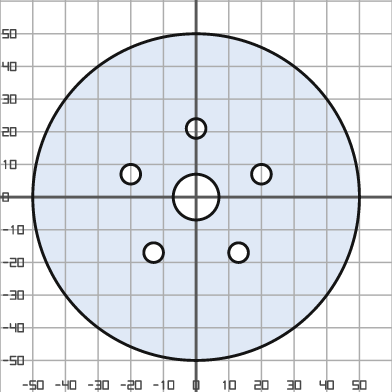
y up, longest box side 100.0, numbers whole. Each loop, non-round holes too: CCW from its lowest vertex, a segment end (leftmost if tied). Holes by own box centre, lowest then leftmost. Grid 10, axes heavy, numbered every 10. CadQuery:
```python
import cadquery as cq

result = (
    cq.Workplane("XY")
    .moveTo(0.0, 0.0)
    .circle(50.0)
    .moveTo(-13.0, -17.0)
    .circle(3.0)
    .moveTo(13.0, -17.0)
    .circle(3.0)
    .moveTo(0.0, 0.0)
    .circle(7.0)
    .moveTo(-20.0, 7.0)
    .circle(3.0)
    .moveTo(20.0, 7.0)
    .circle(3.0)
    .moveTo(0.0, 21.0)
    .circle(3.0)
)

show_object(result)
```